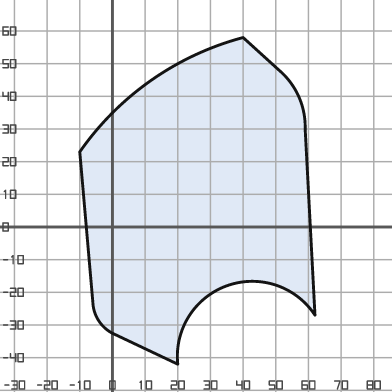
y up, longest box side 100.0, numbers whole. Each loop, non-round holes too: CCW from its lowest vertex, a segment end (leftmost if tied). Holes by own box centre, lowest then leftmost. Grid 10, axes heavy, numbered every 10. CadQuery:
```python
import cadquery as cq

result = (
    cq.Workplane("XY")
    .moveTo(20.0, -42.0)
    .threePointArc((35.0, -18.0), (62.0, -27.0))
    .lineTo(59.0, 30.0)
    .threePointArc((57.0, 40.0), (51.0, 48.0))
    .lineTo(40.0, 58.0)
    .threePointArc((12.0, 45.0), (-10.0, 23.0))
    .lineTo(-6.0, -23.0)
    .threePointArc((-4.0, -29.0), (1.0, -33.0))
    .close()
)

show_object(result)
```